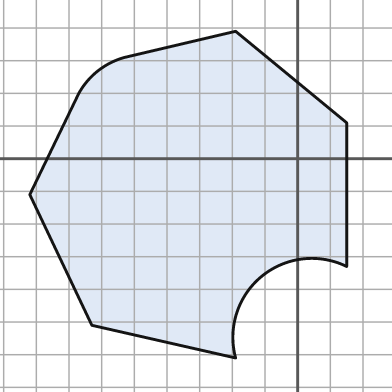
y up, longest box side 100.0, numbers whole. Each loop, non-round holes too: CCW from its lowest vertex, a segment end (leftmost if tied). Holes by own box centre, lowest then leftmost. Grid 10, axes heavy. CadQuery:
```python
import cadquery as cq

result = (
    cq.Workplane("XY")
    .moveTo(-19.0, -61.0)
    .threePointArc((-11.0, -36.0), (15.0, -33.0))
    .lineTo(15.0, 11.0)
    .lineTo(-19.0, 39.0)
    .lineTo(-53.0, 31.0)
    .threePointArc((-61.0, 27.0), (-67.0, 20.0))
    .lineTo(-82.0, -11.0)
    .lineTo(-63.0, -51.0)
    .close()
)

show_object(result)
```